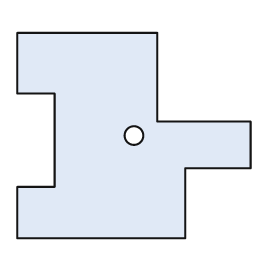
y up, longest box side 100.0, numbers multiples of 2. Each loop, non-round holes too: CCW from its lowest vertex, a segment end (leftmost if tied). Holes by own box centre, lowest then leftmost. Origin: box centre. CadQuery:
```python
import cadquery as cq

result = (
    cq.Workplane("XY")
    .moveTo(-50.0, -44.0)
    .lineTo(22.0, -44.0)
    .lineTo(22.0, -14.0)
    .lineTo(50.0, -14.0)
    .lineTo(50.0, 6.0)
    .lineTo(10.0, 6.0)
    .lineTo(10.0, 44.0)
    .lineTo(-50.0, 44.0)
    .lineTo(-50.0, 18.0)
    .lineTo(-34.0, 18.0)
    .lineTo(-34.0, -22.0)
    .lineTo(-50.0, -22.0)
    .close()
    .moveTo(0.0, 0.0)
    .circle(4.0)
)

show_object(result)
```